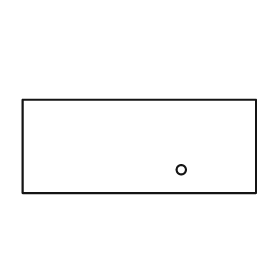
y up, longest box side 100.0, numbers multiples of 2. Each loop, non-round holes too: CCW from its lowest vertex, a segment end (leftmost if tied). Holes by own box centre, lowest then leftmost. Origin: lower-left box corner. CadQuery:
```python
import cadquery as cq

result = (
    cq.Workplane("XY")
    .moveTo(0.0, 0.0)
    .lineTo(100.0, 0.0)
    .lineTo(100.0, 40.0)
    .lineTo(0.0, 40.0)
    .close()
    .moveTo(68.0, 10.0)
    .circle(2.0)
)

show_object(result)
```